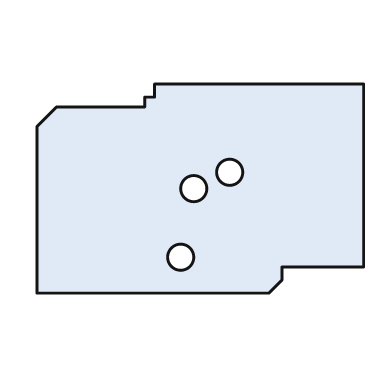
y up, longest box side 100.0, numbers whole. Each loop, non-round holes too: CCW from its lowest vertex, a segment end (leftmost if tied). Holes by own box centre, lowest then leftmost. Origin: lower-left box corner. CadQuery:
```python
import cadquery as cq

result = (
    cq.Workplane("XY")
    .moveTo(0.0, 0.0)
    .lineTo(71.0, 0.0)
    .lineTo(75.0, 4.0)
    .lineTo(75.0, 8.0)
    .lineTo(100.0, 8.0)
    .lineTo(100.0, 64.0)
    .lineTo(36.0, 64.0)
    .lineTo(36.0, 60.0)
    .lineTo(33.0, 60.0)
    .lineTo(33.0, 57.0)
    .lineTo(6.0, 57.0)
    .lineTo(0.0, 51.0)
    .close()
    .moveTo(44.0, 11.0)
    .circle(4.0)
    .moveTo(48.0, 32.0)
    .circle(4.0)
    .moveTo(59.0, 37.0)
    .circle(4.0)
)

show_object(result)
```